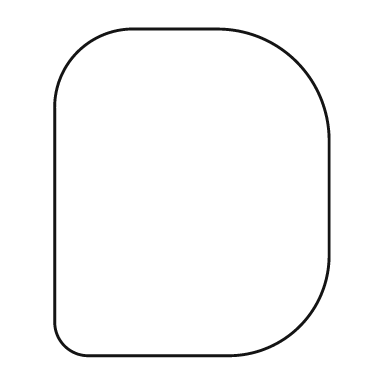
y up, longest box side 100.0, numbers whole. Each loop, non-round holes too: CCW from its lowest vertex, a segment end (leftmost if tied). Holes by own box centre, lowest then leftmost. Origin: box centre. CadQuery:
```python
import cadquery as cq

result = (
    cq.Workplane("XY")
    .moveTo(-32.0, -50.0)
    .lineTo(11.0, -50.0)
    .threePointArc((33.0, -41.0), (42.0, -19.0))
    .lineTo(42.0, 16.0)
    .threePointArc((32.0, 40.0), (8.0, 50.0))
    .lineTo(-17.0, 50.0)
    .threePointArc((-35.0, 43.0), (-42.0, 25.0))
    .lineTo(-42.0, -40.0)
    .threePointArc((-39.0, -47.0), (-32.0, -50.0))
    .close()
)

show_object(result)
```